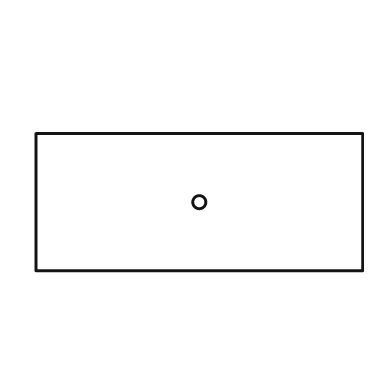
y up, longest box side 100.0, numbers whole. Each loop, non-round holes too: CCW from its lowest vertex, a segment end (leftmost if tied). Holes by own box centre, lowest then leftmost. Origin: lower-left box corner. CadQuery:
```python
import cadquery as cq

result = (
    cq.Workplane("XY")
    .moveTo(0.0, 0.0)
    .lineTo(100.0, 0.0)
    .lineTo(100.0, 42.0)
    .lineTo(0.0, 42.0)
    .close()
    .moveTo(50.0, 21.0)
    .circle(2.0)
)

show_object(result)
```